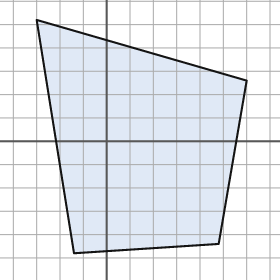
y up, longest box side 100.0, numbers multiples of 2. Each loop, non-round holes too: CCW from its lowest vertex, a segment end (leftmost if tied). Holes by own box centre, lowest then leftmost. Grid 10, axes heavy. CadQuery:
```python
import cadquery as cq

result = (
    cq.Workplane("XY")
    .moveTo(-14.0, -48.0)
    .lineTo(48.0, -44.0)
    .lineTo(60.0, 26.0)
    .lineTo(-30.0, 52.0)
    .close()
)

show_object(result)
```